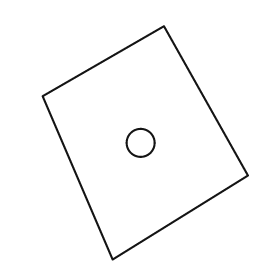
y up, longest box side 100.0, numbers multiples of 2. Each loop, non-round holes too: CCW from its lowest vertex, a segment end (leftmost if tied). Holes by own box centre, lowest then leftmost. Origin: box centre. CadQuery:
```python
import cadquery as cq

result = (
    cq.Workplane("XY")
    .moveTo(-14.0, -50.0)
    .lineTo(44.0, -14.0)
    .lineTo(8.0, 50.0)
    .lineTo(-44.0, 20.0)
    .close()
    .moveTo(-2.0, 0.0)
    .circle(6.0)
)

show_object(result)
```